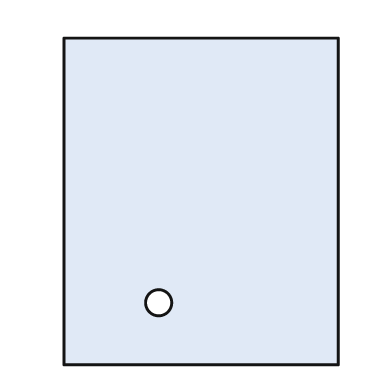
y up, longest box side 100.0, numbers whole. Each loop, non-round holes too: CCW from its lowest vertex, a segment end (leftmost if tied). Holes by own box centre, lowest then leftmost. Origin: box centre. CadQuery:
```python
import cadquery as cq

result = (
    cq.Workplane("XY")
    .moveTo(-42.0, -50.0)
    .lineTo(42.0, -50.0)
    .lineTo(42.0, 50.0)
    .lineTo(-42.0, 50.0)
    .close()
    .moveTo(-13.0, -31.0)
    .circle(4.0)
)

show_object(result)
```